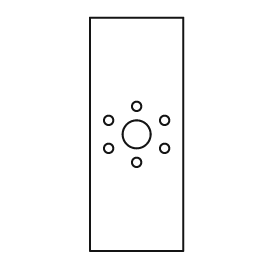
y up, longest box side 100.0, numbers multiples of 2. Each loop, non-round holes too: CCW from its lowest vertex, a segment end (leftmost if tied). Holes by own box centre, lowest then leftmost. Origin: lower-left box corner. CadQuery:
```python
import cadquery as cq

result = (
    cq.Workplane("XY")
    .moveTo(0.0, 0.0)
    .lineTo(40.0, 0.0)
    .lineTo(40.0, 100.0)
    .lineTo(0.0, 100.0)
    .close()
    .moveTo(20.0, 38.0)
    .circle(2.0)
    .moveTo(8.0, 44.0)
    .circle(2.0)
    .moveTo(32.0, 44.0)
    .circle(2.0)
    .moveTo(20.0, 50.0)
    .circle(6.0)
    .moveTo(8.0, 56.0)
    .circle(2.0)
    .moveTo(32.0, 56.0)
    .circle(2.0)
    .moveTo(20.0, 62.0)
    .circle(2.0)
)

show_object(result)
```